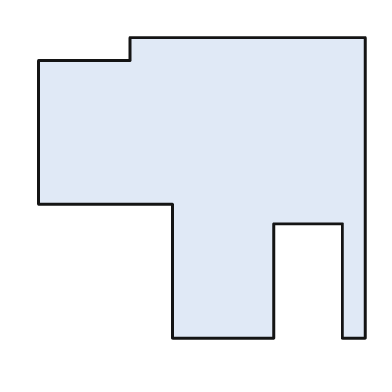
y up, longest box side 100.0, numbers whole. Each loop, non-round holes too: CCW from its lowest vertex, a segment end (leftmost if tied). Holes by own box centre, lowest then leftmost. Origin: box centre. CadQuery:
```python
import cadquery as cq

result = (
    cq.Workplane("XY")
    .moveTo(-9.0, -46.0)
    .lineTo(22.0, -46.0)
    .lineTo(22.0, -11.0)
    .lineTo(43.0, -11.0)
    .lineTo(43.0, -46.0)
    .lineTo(50.0, -46.0)
    .lineTo(50.0, 46.0)
    .lineTo(-22.0, 46.0)
    .lineTo(-22.0, 39.0)
    .lineTo(-50.0, 39.0)
    .lineTo(-50.0, -5.0)
    .lineTo(-9.0, -5.0)
    .close()
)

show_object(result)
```